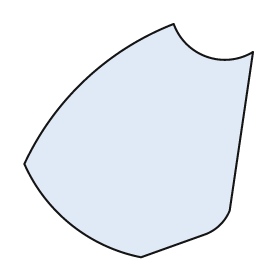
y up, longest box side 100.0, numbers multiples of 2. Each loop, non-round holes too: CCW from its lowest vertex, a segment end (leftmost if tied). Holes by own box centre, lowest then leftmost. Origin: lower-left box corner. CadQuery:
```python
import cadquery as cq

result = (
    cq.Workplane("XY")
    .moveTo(50.0, 0.0)
    .lineTo(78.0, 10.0)
    .threePointArc((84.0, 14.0), (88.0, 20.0))
    .lineTo(98.0, 88.0)
    .threePointArc((78.0, 86.0), (64.0, 100.0))
    .threePointArc((26.0, 76.0), (0.0, 40.0))
    .threePointArc((20.0, 14.0), (50.0, 0.0))
    .close()
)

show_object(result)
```